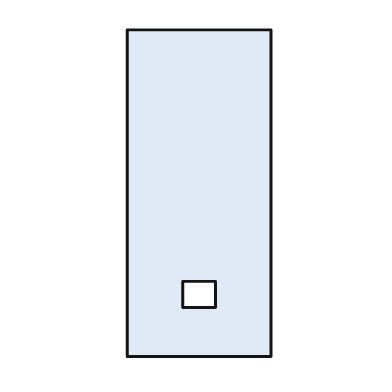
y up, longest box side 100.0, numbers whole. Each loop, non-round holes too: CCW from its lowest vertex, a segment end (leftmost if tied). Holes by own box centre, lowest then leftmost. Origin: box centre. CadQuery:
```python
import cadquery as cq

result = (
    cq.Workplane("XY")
    .moveTo(-22.0, -50.0)
    .lineTo(22.0, -50.0)
    .lineTo(22.0, 50.0)
    .lineTo(-22.0, 50.0)
    .close()
    .moveTo(-5.0, -35.0)
    .lineTo(5.0, -35.0)
    .lineTo(5.0, -27.0)
    .lineTo(-5.0, -27.0)
    .close()
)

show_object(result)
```